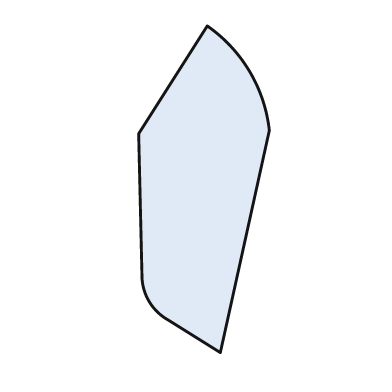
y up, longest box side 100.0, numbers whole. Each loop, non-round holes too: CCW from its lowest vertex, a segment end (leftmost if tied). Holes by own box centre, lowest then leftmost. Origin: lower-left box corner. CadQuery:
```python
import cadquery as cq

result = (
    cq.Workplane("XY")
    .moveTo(25.0, 0.0)
    .lineTo(40.0, 68.0)
    .threePointArc((34.0, 86.0), (21.0, 100.0))
    .lineTo(0.0, 67.0)
    .lineTo(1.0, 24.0)
    .threePointArc((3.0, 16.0), (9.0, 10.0))
    .close()
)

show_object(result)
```